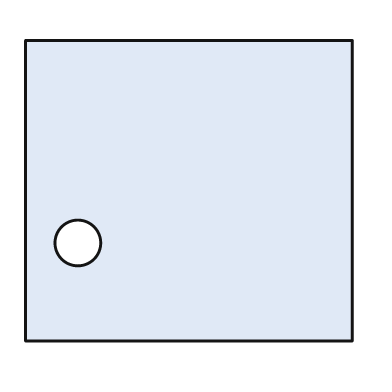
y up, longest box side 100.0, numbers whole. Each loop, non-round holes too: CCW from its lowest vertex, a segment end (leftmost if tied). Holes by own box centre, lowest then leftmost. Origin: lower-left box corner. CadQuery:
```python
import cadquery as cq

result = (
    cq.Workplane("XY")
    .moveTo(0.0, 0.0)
    .lineTo(100.0, 0.0)
    .lineTo(100.0, 92.0)
    .lineTo(0.0, 92.0)
    .close()
    .moveTo(16.0, 30.0)
    .circle(7.0)
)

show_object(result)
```